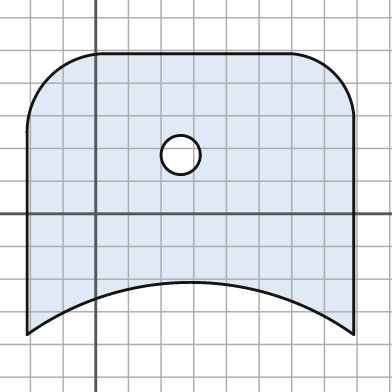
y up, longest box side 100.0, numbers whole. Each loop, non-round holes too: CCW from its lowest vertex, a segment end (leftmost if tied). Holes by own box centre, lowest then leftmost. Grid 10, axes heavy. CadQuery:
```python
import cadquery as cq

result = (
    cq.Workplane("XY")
    .moveTo(-21.0, -37.0)
    .threePointArc((29.0, -21.0), (79.0, -37.0))
    .lineTo(79.0, 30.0)
    .threePointArc((73.0, 43.0), (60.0, 49.0))
    .lineTo(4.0, 49.0)
    .threePointArc((-14.0, 42.0), (-21.0, 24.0))
    .close()
    .moveTo(26.0, 18.0)
    .circle(6.0)
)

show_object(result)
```